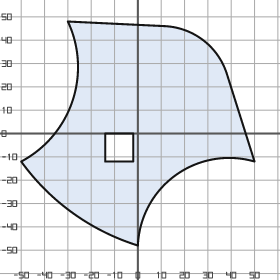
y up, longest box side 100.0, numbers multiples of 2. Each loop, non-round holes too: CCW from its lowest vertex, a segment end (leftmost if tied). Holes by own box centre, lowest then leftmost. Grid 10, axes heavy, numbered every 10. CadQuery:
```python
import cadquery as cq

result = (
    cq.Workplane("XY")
    .moveTo(0.0, -48.0)
    .threePointArc((16.0, -18.0), (50.0, -12.0))
    .lineTo(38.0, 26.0)
    .threePointArc((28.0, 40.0), (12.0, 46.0))
    .lineTo(-30.0, 48.0)
    .threePointArc((-28.0, 14.0), (-50.0, -12.0))
    .threePointArc((-28.0, -34.0), (0.0, -48.0))
    .close()
    .moveTo(-14.0, -12.0)
    .lineTo(-2.0, -12.0)
    .lineTo(-2.0, 0.0)
    .lineTo(-14.0, 0.0)
    .close()
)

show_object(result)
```